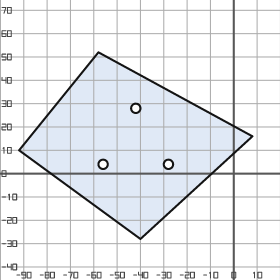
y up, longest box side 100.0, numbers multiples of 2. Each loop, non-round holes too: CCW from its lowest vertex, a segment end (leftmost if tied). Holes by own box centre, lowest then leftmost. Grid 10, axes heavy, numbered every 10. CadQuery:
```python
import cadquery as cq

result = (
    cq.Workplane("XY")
    .moveTo(-40.0, -28.0)
    .lineTo(8.0, 16.0)
    .lineTo(-58.0, 52.0)
    .lineTo(-92.0, 10.0)
    .close()
    .moveTo(-56.0, 4.0)
    .circle(2.0)
    .moveTo(-28.0, 4.0)
    .circle(2.0)
    .moveTo(-42.0, 28.0)
    .circle(2.0)
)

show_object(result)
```